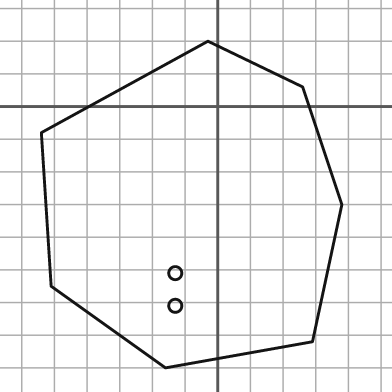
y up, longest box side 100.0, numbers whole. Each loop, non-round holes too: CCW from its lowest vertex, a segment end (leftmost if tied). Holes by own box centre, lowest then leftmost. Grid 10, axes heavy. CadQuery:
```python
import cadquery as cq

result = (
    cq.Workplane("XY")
    .moveTo(-16.0, -80.0)
    .lineTo(29.0, -72.0)
    .lineTo(38.0, -30.0)
    .lineTo(26.0, 6.0)
    .lineTo(-3.0, 20.0)
    .lineTo(-54.0, -8.0)
    .lineTo(-51.0, -55.0)
    .close()
    .moveTo(-13.0, -61.0)
    .circle(2.0)
    .moveTo(-13.0, -51.0)
    .circle(2.0)
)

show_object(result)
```